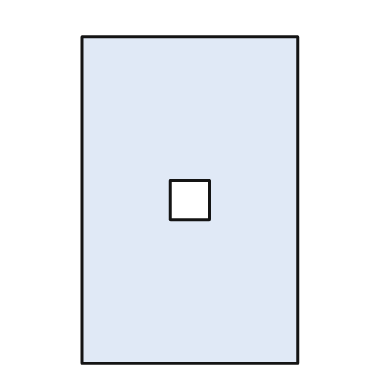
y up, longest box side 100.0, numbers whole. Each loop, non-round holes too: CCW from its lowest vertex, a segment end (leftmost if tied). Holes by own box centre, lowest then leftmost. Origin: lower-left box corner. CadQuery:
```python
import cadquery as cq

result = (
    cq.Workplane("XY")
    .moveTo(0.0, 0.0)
    .lineTo(66.0, 0.0)
    .lineTo(66.0, 100.0)
    .lineTo(0.0, 100.0)
    .close()
    .moveTo(27.0, 44.0)
    .lineTo(39.0, 44.0)
    .lineTo(39.0, 56.0)
    .lineTo(27.0, 56.0)
    .close()
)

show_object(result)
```